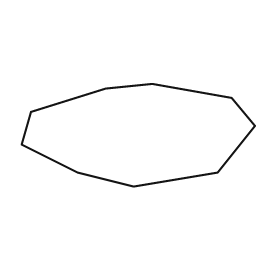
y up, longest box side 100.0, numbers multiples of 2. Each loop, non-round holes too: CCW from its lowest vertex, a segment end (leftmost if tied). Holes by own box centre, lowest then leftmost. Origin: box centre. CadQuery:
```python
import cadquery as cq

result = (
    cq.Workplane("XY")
    .moveTo(-2.0, -22.0)
    .lineTo(34.0, -16.0)
    .lineTo(50.0, 4.0)
    .lineTo(40.0, 16.0)
    .lineTo(6.0, 22.0)
    .lineTo(-14.0, 20.0)
    .lineTo(-46.0, 10.0)
    .lineTo(-50.0, -4.0)
    .lineTo(-26.0, -16.0)
    .close()
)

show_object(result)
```